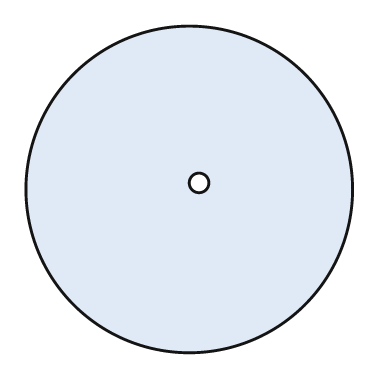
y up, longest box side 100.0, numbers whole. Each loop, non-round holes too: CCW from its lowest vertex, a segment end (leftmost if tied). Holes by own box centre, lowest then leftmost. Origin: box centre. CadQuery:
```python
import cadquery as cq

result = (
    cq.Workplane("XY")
    .moveTo(0.0, 0.0)
    .circle(50.0)
    .moveTo(3.0, 2.0)
    .circle(3.0)
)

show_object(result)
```